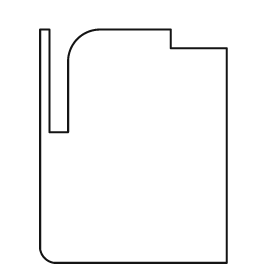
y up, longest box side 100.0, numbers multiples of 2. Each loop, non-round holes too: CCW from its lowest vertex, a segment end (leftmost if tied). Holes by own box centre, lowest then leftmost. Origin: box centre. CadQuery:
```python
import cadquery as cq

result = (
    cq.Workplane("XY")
    .moveTo(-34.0, -50.0)
    .lineTo(40.0, -50.0)
    .lineTo(40.0, 42.0)
    .lineTo(16.0, 42.0)
    .lineTo(16.0, 50.0)
    .lineTo(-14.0, 50.0)
    .threePointArc((-24.0, 46.0), (-28.0, 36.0))
    .lineTo(-28.0, 6.0)
    .lineTo(-36.0, 6.0)
    .lineTo(-36.0, 50.0)
    .lineTo(-40.0, 50.0)
    .lineTo(-40.0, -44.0)
    .threePointArc((-38.0, -48.0), (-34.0, -50.0))
    .close()
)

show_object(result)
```